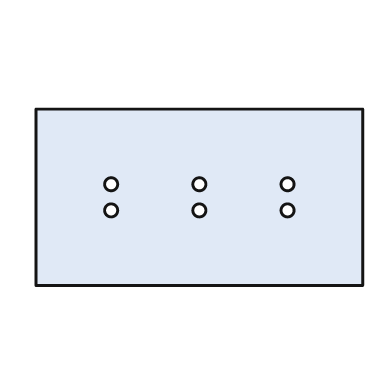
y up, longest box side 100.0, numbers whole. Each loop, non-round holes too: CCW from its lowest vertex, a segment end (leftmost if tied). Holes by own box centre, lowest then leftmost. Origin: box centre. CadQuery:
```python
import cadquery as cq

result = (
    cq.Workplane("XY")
    .moveTo(-50.0, -27.0)
    .lineTo(50.0, -27.0)
    .lineTo(50.0, 27.0)
    .lineTo(-50.0, 27.0)
    .close()
    .moveTo(-27.0, -4.0)
    .circle(2.0)
    .moveTo(0.0, -4.0)
    .circle(2.0)
    .moveTo(27.0, -4.0)
    .circle(2.0)
    .moveTo(-27.0, 4.0)
    .circle(2.0)
    .moveTo(0.0, 4.0)
    .circle(2.0)
    .moveTo(27.0, 4.0)
    .circle(2.0)
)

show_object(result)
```